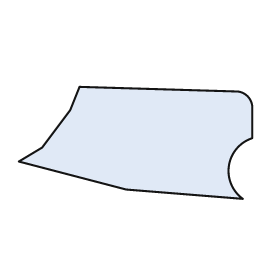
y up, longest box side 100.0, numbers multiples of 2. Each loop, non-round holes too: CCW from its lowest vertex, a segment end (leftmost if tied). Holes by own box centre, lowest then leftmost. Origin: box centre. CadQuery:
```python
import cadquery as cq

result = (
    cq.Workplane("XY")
    .moveTo(46.0, -24.0)
    .threePointArc((40.0, -10.0), (50.0, 2.0))
    .lineTo(50.0, 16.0)
    .threePointArc((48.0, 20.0), (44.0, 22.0))
    .lineTo(-24.0, 24.0)
    .lineTo(-28.0, 14.0)
    .lineTo(-40.0, -2.0)
    .lineTo(-50.0, -8.0)
    .lineTo(-4.0, -20.0)
    .close()
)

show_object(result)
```